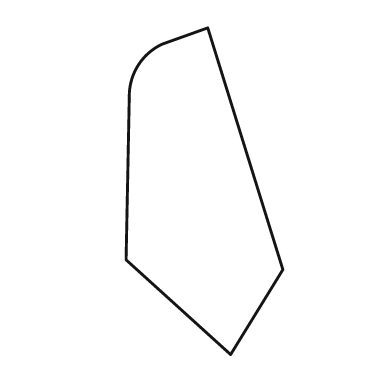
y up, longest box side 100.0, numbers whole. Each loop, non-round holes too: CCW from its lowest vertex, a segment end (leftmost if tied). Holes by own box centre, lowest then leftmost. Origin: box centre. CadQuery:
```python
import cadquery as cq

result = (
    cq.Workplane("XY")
    .moveTo(8.0, -50.0)
    .lineTo(24.0, -24.0)
    .lineTo(1.0, 50.0)
    .lineTo(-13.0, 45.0)
    .threePointArc((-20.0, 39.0), (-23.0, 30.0))
    .lineTo(-24.0, -21.0)
    .close()
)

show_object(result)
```